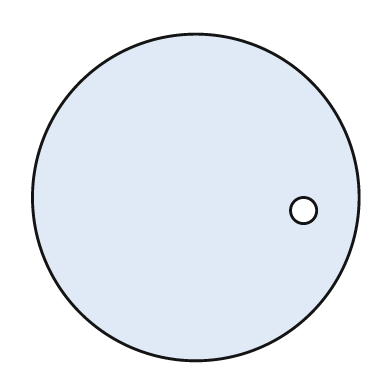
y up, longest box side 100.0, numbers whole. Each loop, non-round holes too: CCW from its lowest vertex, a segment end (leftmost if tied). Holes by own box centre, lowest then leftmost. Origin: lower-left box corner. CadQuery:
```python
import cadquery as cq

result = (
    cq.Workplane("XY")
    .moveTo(50.0, 50.0)
    .circle(50.0)
    .moveTo(83.0, 46.0)
    .circle(4.0)
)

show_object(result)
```